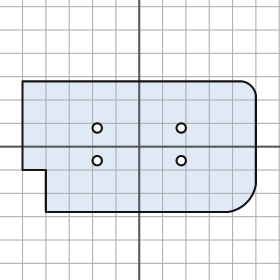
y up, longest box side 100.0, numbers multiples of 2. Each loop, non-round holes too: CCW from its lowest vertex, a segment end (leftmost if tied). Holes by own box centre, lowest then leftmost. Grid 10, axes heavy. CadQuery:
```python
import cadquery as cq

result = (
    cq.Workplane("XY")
    .moveTo(-40.0, -28.0)
    .lineTo(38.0, -28.0)
    .threePointArc((46.0, -24.0), (50.0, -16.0))
    .lineTo(50.0, 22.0)
    .threePointArc((48.0, 26.0), (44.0, 28.0))
    .lineTo(-50.0, 28.0)
    .lineTo(-50.0, -10.0)
    .lineTo(-40.0, -10.0)
    .close()
    .moveTo(-18.0, -6.0)
    .circle(2.0)
    .moveTo(18.0, -6.0)
    .circle(2.0)
    .moveTo(-18.0, 8.0)
    .circle(2.0)
    .moveTo(18.0, 8.0)
    .circle(2.0)
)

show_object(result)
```